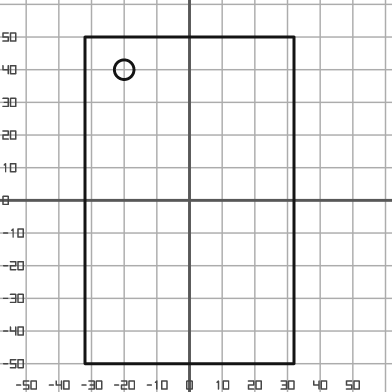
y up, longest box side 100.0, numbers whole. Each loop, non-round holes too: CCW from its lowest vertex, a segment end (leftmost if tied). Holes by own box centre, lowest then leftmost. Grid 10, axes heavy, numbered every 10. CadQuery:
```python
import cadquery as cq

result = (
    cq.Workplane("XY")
    .moveTo(-32.0, -50.0)
    .lineTo(32.0, -50.0)
    .lineTo(32.0, 50.0)
    .lineTo(-32.0, 50.0)
    .close()
    .moveTo(-20.0, 40.0)
    .circle(3.0)
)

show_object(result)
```